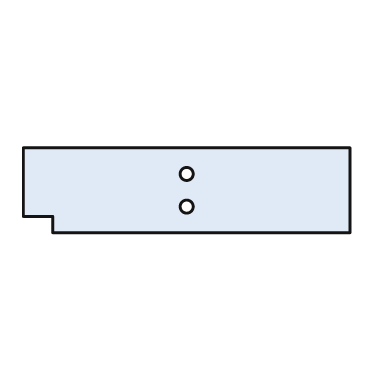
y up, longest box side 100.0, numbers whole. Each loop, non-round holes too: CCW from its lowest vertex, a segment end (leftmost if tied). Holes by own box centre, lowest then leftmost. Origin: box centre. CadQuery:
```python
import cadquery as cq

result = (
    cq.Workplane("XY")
    .moveTo(-41.0, -13.0)
    .lineTo(50.0, -13.0)
    .lineTo(50.0, 13.0)
    .lineTo(-50.0, 13.0)
    .lineTo(-50.0, -8.0)
    .lineTo(-41.0, -8.0)
    .close()
    .moveTo(0.0, -5.0)
    .circle(2.0)
    .moveTo(0.0, 5.0)
    .circle(2.0)
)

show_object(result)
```